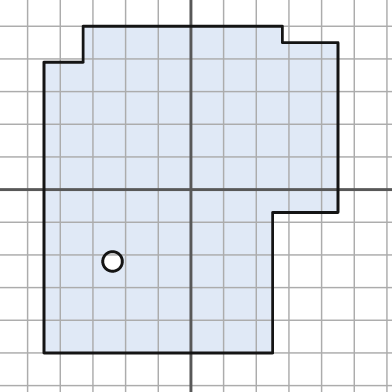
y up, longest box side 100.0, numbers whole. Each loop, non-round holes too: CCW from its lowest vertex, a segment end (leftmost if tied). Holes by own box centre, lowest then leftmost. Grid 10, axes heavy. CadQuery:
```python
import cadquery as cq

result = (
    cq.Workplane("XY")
    .moveTo(-45.0, -50.0)
    .lineTo(25.0, -50.0)
    .lineTo(25.0, -7.0)
    .lineTo(45.0, -7.0)
    .lineTo(45.0, 45.0)
    .lineTo(28.0, 45.0)
    .lineTo(28.0, 50.0)
    .lineTo(-33.0, 50.0)
    .lineTo(-33.0, 39.0)
    .lineTo(-45.0, 39.0)
    .close()
    .moveTo(-24.0, -22.0)
    .circle(3.0)
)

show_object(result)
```